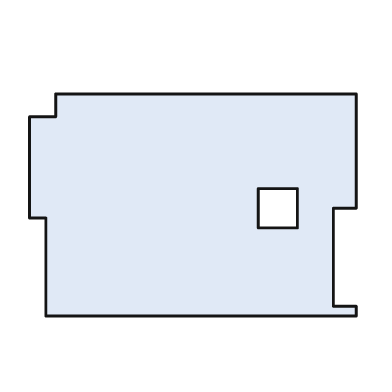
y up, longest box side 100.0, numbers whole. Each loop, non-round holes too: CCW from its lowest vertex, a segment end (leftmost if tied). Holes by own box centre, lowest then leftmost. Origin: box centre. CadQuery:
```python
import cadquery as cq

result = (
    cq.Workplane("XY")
    .moveTo(-45.0, -34.0)
    .lineTo(50.0, -34.0)
    .lineTo(50.0, -31.0)
    .lineTo(43.0, -31.0)
    .lineTo(43.0, -1.0)
    .lineTo(50.0, -1.0)
    .lineTo(50.0, 34.0)
    .lineTo(-42.0, 34.0)
    .lineTo(-42.0, 27.0)
    .lineTo(-50.0, 27.0)
    .lineTo(-50.0, -4.0)
    .lineTo(-45.0, -4.0)
    .close()
    .moveTo(20.0, -7.0)
    .lineTo(32.0, -7.0)
    .lineTo(32.0, 5.0)
    .lineTo(20.0, 5.0)
    .close()
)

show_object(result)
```